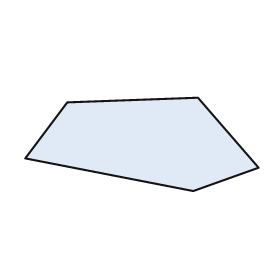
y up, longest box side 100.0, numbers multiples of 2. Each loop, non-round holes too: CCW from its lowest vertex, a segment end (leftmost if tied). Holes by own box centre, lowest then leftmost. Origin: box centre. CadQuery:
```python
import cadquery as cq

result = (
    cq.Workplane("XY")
    .moveTo(22.0, -20.0)
    .lineTo(50.0, -10.0)
    .lineTo(24.0, 20.0)
    .lineTo(-32.0, 18.0)
    .lineTo(-50.0, -6.0)
    .close()
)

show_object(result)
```